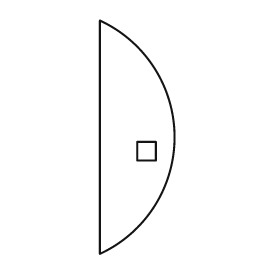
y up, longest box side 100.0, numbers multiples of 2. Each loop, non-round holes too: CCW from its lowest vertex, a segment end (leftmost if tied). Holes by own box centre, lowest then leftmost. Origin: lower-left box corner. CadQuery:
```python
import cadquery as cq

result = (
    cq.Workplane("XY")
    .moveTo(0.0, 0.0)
    .threePointArc((32.0, 50.0), (0.0, 100.0))
    .close()
    .moveTo(16.0, 40.0)
    .lineTo(24.0, 40.0)
    .lineTo(24.0, 48.0)
    .lineTo(16.0, 48.0)
    .close()
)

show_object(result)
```